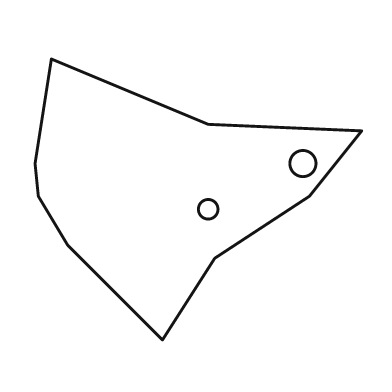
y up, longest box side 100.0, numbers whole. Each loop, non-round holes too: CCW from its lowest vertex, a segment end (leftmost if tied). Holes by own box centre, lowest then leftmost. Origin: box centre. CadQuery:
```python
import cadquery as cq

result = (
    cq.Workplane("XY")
    .moveTo(-11.0, -43.0)
    .lineTo(5.0, -18.0)
    .lineTo(34.0, 1.0)
    .lineTo(50.0, 21.0)
    .lineTo(3.0, 23.0)
    .lineTo(-45.0, 43.0)
    .lineTo(-50.0, 11.0)
    .lineTo(-49.0, 1.0)
    .lineTo(-40.0, -14.0)
    .close()
    .moveTo(3.0, -3.0)
    .circle(3.0)
    .moveTo(32.0, 11.0)
    .circle(4.0)
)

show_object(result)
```